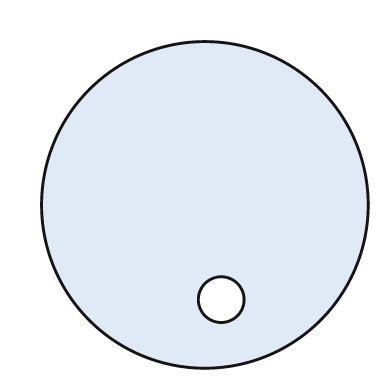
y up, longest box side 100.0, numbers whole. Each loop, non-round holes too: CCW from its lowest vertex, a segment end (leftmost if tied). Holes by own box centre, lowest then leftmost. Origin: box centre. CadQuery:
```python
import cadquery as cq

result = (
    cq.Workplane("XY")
    .moveTo(0.0, 0.0)
    .circle(50.0)
    .moveTo(5.0, -29.0)
    .circle(7.0)
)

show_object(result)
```